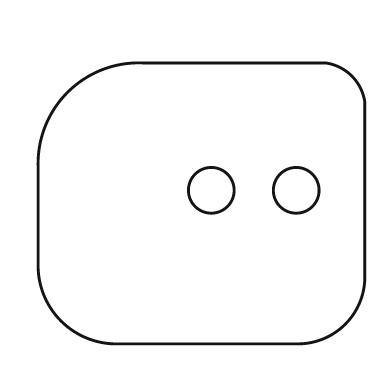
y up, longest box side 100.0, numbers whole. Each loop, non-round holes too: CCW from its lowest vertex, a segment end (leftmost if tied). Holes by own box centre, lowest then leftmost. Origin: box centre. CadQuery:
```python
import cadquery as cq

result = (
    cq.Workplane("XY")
    .moveTo(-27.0, -43.0)
    .lineTo(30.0, -43.0)
    .threePointArc((44.0, -37.0), (50.0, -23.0))
    .lineTo(50.0, 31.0)
    .threePointArc((46.0, 39.0), (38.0, 43.0))
    .lineTo(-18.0, 43.0)
    .threePointArc((-41.0, 34.0), (-50.0, 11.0))
    .lineTo(-50.0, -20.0)
    .threePointArc((-43.0, -36.0), (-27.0, -43.0))
    .close()
    .moveTo(3.0, 4.0)
    .circle(7.0)
    .moveTo(29.0, 4.0)
    .circle(7.0)
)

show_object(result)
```